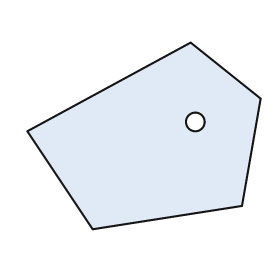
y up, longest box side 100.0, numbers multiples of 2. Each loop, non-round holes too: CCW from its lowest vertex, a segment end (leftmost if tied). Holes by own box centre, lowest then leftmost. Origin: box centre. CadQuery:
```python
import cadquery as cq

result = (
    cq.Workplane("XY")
    .moveTo(-22.0, -40.0)
    .lineTo(42.0, -30.0)
    .lineTo(50.0, 16.0)
    .lineTo(20.0, 40.0)
    .lineTo(-50.0, 2.0)
    .close()
    .moveTo(22.0, 6.0)
    .circle(4.0)
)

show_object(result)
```